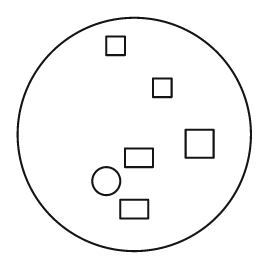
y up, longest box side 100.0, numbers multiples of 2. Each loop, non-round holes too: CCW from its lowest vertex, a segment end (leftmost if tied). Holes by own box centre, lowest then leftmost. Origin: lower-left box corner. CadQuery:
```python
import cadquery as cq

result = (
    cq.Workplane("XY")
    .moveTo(50.0, 50.0)
    .circle(50.0)
    .moveTo(44.0, 14.0)
    .lineTo(56.0, 14.0)
    .lineTo(56.0, 22.0)
    .lineTo(44.0, 22.0)
    .close()
    .moveTo(38.0, 30.0)
    .circle(6.0)
    .moveTo(46.0, 36.0)
    .lineTo(58.0, 36.0)
    .lineTo(58.0, 44.0)
    .lineTo(46.0, 44.0)
    .close()
    .moveTo(72.0, 40.0)
    .lineTo(84.0, 40.0)
    .lineTo(84.0, 52.0)
    .lineTo(72.0, 52.0)
    .close()
    .moveTo(58.0, 66.0)
    .lineTo(66.0, 66.0)
    .lineTo(66.0, 74.0)
    .lineTo(58.0, 74.0)
    .close()
    .moveTo(38.0, 84.0)
    .lineTo(46.0, 84.0)
    .lineTo(46.0, 92.0)
    .lineTo(38.0, 92.0)
    .close()
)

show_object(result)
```